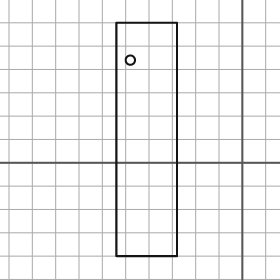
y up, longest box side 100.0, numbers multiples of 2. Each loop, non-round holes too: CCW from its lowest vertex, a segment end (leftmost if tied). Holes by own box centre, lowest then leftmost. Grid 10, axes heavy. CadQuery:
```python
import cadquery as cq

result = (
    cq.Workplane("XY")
    .moveTo(-54.0, -40.0)
    .lineTo(-28.0, -40.0)
    .lineTo(-28.0, 60.0)
    .lineTo(-54.0, 60.0)
    .close()
    .moveTo(-48.0, 44.0)
    .circle(2.0)
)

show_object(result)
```